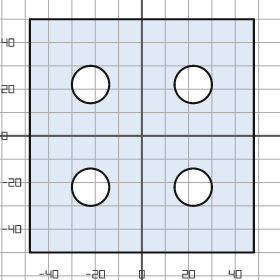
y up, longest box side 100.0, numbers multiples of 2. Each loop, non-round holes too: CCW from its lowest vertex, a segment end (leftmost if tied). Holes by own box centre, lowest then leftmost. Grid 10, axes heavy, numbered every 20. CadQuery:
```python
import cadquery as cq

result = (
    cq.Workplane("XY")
    .moveTo(-48.0, -50.0)
    .lineTo(48.0, -50.0)
    .lineTo(48.0, 50.0)
    .lineTo(-48.0, 50.0)
    .close()
    .moveTo(-22.0, -22.0)
    .circle(8.0)
    .moveTo(22.0, -22.0)
    .circle(8.0)
    .moveTo(-22.0, 22.0)
    .circle(8.0)
    .moveTo(22.0, 22.0)
    .circle(8.0)
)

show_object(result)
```